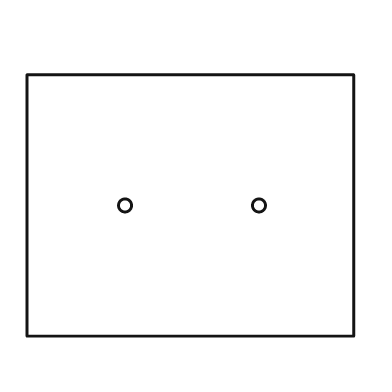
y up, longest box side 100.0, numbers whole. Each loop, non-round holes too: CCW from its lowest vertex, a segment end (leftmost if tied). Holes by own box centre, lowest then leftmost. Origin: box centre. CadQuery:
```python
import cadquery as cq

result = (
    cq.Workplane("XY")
    .moveTo(-50.0, -40.0)
    .lineTo(50.0, -40.0)
    .lineTo(50.0, 40.0)
    .lineTo(-50.0, 40.0)
    .close()
    .moveTo(-20.0, 0.0)
    .circle(2.0)
    .moveTo(21.0, 0.0)
    .circle(2.0)
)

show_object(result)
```